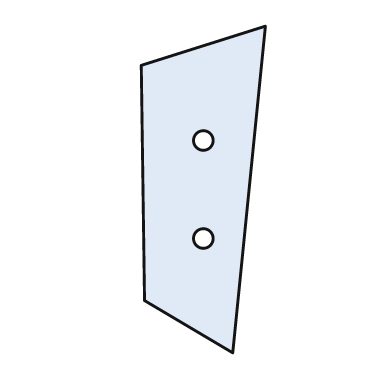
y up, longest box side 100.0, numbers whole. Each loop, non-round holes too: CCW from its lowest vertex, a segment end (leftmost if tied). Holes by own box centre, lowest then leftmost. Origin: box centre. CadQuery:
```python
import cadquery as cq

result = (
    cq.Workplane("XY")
    .moveTo(9.0, -50.0)
    .lineTo(19.0, 50.0)
    .lineTo(-19.0, 38.0)
    .lineTo(-18.0, -34.0)
    .close()
    .moveTo(0.0, -15.0)
    .circle(3.0)
    .moveTo(0.0, 15.0)
    .circle(3.0)
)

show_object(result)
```